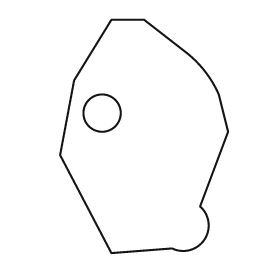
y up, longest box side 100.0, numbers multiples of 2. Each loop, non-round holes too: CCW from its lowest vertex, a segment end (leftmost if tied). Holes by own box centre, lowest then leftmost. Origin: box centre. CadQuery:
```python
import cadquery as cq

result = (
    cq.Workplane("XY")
    .moveTo(-14.0, -50.0)
    .lineTo(12.0, -48.0)
    .threePointArc((26.0, -44.0), (24.0, -30.0))
    .lineTo(36.0, 2.0)
    .lineTo(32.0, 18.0)
    .threePointArc((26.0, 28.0), (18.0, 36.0))
    .lineTo(0.0, 50.0)
    .lineTo(-14.0, 50.0)
    .lineTo(-30.0, 24.0)
    .lineTo(-36.0, -8.0)
    .close()
    .moveTo(-18.0, 10.0)
    .circle(8.0)
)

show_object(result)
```